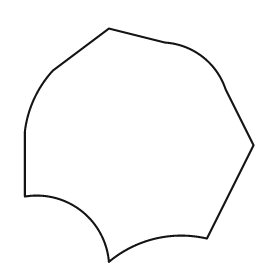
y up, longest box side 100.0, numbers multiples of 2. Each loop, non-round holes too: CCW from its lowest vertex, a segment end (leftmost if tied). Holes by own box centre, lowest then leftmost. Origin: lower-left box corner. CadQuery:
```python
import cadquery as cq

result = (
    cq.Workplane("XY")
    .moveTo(36.0, 0.0)
    .threePointArc((56.0, 10.0), (78.0, 10.0))
    .lineTo(98.0, 50.0)
    .lineTo(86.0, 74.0)
    .threePointArc((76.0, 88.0), (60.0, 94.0))
    .lineTo(36.0, 100.0)
    .lineTo(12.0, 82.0)
    .threePointArc((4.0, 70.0), (0.0, 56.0))
    .lineTo(0.0, 28.0)
    .threePointArc((24.0, 22.0), (36.0, 0.0))
    .close()
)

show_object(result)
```